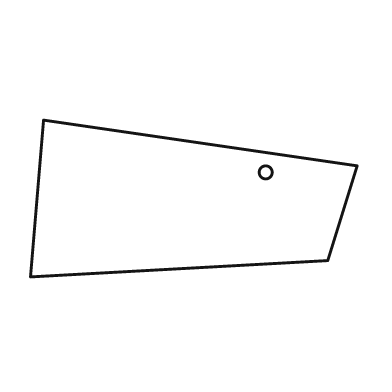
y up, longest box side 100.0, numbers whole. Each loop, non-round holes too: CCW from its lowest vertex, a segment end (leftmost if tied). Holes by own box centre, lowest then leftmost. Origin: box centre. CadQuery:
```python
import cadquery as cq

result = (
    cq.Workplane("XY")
    .moveTo(-50.0, -24.0)
    .lineTo(41.0, -19.0)
    .lineTo(50.0, 10.0)
    .lineTo(-46.0, 24.0)
    .close()
    .moveTo(22.0, 8.0)
    .circle(2.0)
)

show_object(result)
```